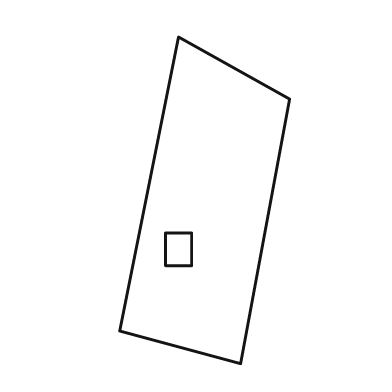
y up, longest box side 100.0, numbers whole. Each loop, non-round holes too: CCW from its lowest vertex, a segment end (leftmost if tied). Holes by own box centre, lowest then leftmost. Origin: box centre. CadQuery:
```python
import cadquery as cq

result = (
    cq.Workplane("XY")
    .moveTo(11.0, -50.0)
    .lineTo(26.0, 31.0)
    .lineTo(-8.0, 50.0)
    .lineTo(-26.0, -40.0)
    .close()
    .moveTo(-12.0, -20.0)
    .lineTo(-4.0, -20.0)
    .lineTo(-4.0, -10.0)
    .lineTo(-12.0, -10.0)
    .close()
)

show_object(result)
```